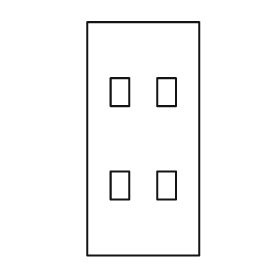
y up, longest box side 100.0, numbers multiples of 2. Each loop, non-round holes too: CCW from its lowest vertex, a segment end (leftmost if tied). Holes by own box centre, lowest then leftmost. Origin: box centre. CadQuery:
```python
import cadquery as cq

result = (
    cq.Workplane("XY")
    .moveTo(-24.0, -50.0)
    .lineTo(24.0, -50.0)
    .lineTo(24.0, 50.0)
    .lineTo(-24.0, 50.0)
    .close()
    .moveTo(-14.0, -26.0)
    .lineTo(-6.0, -26.0)
    .lineTo(-6.0, -14.0)
    .lineTo(-14.0, -14.0)
    .close()
    .moveTo(6.0, -26.0)
    .lineTo(14.0, -26.0)
    .lineTo(14.0, -14.0)
    .lineTo(6.0, -14.0)
    .close()
    .moveTo(-14.0, 14.0)
    .lineTo(-6.0, 14.0)
    .lineTo(-6.0, 26.0)
    .lineTo(-14.0, 26.0)
    .close()
    .moveTo(6.0, 14.0)
    .lineTo(14.0, 14.0)
    .lineTo(14.0, 26.0)
    .lineTo(6.0, 26.0)
    .close()
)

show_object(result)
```